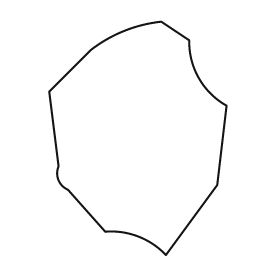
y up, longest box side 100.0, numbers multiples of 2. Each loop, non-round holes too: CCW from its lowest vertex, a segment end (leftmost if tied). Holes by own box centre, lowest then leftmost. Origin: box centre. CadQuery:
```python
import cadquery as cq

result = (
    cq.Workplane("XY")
    .moveTo(12.0, -50.0)
    .lineTo(34.0, -20.0)
    .lineTo(38.0, 14.0)
    .threePointArc((26.0, 26.0), (22.0, 42.0))
    .lineTo(10.0, 50.0)
    .threePointArc((-6.0, 46.0), (-20.0, 38.0))
    .lineTo(-38.0, 20.0)
    .lineTo(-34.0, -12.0)
    .threePointArc((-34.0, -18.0), (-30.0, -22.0))
    .lineTo(-14.0, -40.0)
    .threePointArc((0.0, -42.0), (12.0, -50.0))
    .close()
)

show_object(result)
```